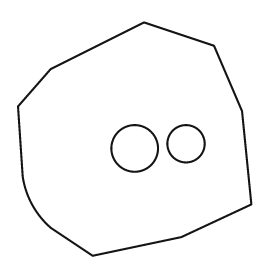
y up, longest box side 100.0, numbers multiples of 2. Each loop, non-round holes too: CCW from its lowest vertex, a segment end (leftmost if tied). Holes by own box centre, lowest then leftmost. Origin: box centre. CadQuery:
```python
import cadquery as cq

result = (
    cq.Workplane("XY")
    .moveTo(-18.0, -50.0)
    .lineTo(20.0, -42.0)
    .lineTo(50.0, -28.0)
    .lineTo(46.0, 12.0)
    .lineTo(34.0, 40.0)
    .lineTo(4.0, 50.0)
    .lineTo(-36.0, 30.0)
    .lineTo(-50.0, 14.0)
    .lineTo(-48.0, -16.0)
    .threePointArc((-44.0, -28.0), (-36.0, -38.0))
    .close()
    .moveTo(0.0, -4.0)
    .circle(10.0)
    .moveTo(22.0, -2.0)
    .circle(8.0)
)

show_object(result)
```